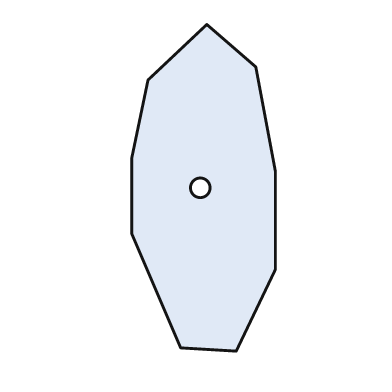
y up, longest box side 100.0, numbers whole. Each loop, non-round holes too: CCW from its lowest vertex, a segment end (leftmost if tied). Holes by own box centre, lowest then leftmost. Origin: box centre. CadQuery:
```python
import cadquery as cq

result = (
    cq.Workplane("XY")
    .moveTo(10.0, -50.0)
    .lineTo(22.0, -25.0)
    .lineTo(22.0, 5.0)
    .lineTo(16.0, 37.0)
    .lineTo(1.0, 50.0)
    .lineTo(-17.0, 33.0)
    .lineTo(-22.0, 9.0)
    .lineTo(-22.0, -14.0)
    .lineTo(-7.0, -49.0)
    .close()
    .moveTo(-1.0, 0.0)
    .circle(3.0)
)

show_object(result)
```